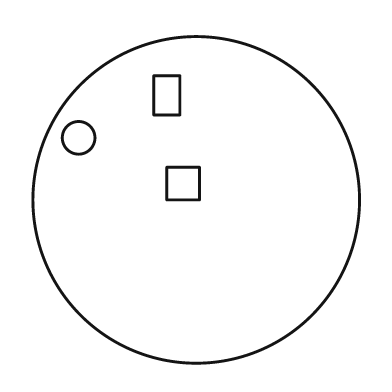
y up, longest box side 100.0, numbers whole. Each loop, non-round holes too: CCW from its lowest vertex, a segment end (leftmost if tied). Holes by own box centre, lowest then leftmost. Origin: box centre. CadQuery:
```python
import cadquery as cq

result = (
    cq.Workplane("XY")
    .moveTo(0.0, 0.0)
    .circle(50.0)
    .moveTo(-9.0, 0.0)
    .lineTo(1.0, 0.0)
    .lineTo(1.0, 10.0)
    .lineTo(-9.0, 10.0)
    .close()
    .moveTo(-36.0, 19.0)
    .circle(5.0)
    .moveTo(-13.0, 26.0)
    .lineTo(-5.0, 26.0)
    .lineTo(-5.0, 38.0)
    .lineTo(-13.0, 38.0)
    .close()
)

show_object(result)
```